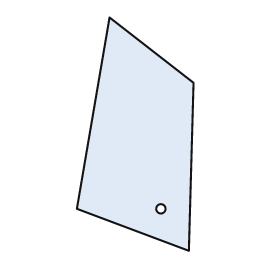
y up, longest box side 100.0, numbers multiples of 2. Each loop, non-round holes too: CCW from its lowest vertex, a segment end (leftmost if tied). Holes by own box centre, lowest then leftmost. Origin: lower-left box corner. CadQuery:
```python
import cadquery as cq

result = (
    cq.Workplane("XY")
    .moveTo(48.0, 0.0)
    .lineTo(50.0, 72.0)
    .lineTo(14.0, 100.0)
    .lineTo(0.0, 18.0)
    .close()
    .moveTo(36.0, 18.0)
    .circle(2.0)
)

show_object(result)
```